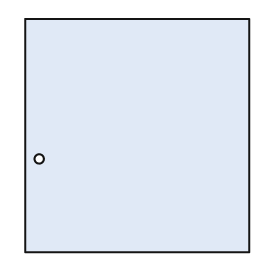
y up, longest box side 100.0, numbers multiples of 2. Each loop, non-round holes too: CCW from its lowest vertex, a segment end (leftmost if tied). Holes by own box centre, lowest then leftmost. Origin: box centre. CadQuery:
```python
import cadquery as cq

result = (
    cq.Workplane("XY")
    .moveTo(-48.0, -50.0)
    .lineTo(48.0, -50.0)
    .lineTo(48.0, 50.0)
    .lineTo(-48.0, 50.0)
    .close()
    .moveTo(-42.0, -10.0)
    .circle(2.0)
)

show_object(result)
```